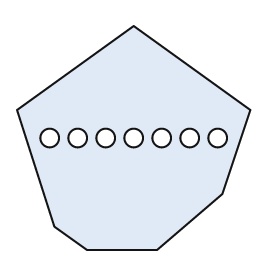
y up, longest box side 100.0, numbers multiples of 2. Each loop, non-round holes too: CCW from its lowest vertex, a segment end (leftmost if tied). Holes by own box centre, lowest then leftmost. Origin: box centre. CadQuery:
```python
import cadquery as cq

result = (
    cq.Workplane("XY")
    .moveTo(-20.0, -48.0)
    .lineTo(10.0, -48.0)
    .lineTo(38.0, -24.0)
    .lineTo(50.0, 12.0)
    .lineTo(0.0, 48.0)
    .lineTo(-50.0, 12.0)
    .lineTo(-34.0, -38.0)
    .close()
    .moveTo(-36.0, 0.0)
    .circle(4.0)
    .moveTo(-24.0, 0.0)
    .circle(4.0)
    .moveTo(-12.0, 0.0)
    .circle(4.0)
    .moveTo(0.0, 0.0)
    .circle(4.0)
    .moveTo(12.0, 0.0)
    .circle(4.0)
    .moveTo(24.0, 0.0)
    .circle(4.0)
    .moveTo(36.0, 0.0)
    .circle(4.0)
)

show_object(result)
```